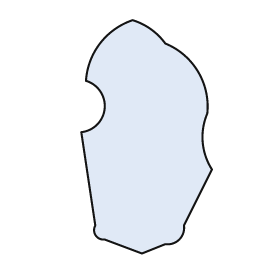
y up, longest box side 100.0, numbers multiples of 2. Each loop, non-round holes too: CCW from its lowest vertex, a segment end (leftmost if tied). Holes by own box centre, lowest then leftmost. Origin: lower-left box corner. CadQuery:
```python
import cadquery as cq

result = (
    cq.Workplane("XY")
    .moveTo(26.0, 0.0)
    .lineTo(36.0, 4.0)
    .threePointArc((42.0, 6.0), (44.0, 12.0))
    .lineTo(56.0, 36.0)
    .threePointArc((52.0, 48.0), (54.0, 60.0))
    .threePointArc((50.0, 78.0), (36.0, 90.0))
    .threePointArc((30.0, 96.0), (22.0, 100.0))
    .threePointArc((8.0, 90.0), (2.0, 74.0))
    .threePointArc((10.0, 62.0), (0.0, 52.0))
    .lineTo(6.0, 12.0)
    .threePointArc((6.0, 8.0), (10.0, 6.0))
    .close()
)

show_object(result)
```